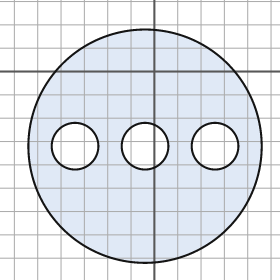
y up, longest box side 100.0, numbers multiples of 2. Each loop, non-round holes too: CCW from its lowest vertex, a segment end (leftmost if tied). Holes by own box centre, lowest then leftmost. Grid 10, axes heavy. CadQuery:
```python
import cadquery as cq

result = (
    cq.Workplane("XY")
    .moveTo(-4.0, -32.0)
    .circle(50.0)
    .moveTo(-34.0, -32.0)
    .circle(10.0)
    .moveTo(-4.0, -32.0)
    .circle(10.0)
    .moveTo(26.0, -32.0)
    .circle(10.0)
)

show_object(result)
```